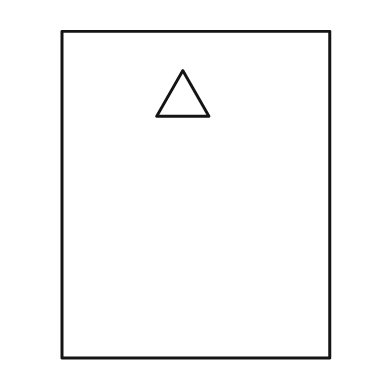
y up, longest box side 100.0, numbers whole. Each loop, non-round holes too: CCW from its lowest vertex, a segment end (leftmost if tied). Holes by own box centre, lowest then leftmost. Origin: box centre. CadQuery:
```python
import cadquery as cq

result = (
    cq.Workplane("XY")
    .moveTo(-41.0, -50.0)
    .lineTo(41.0, -50.0)
    .lineTo(41.0, 50.0)
    .lineTo(-41.0, 50.0)
    .close()
    .moveTo(-12.0, 24.0)
    .lineTo(4.0, 24.0)
    .lineTo(-4.0, 38.0)
    .close()
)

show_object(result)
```